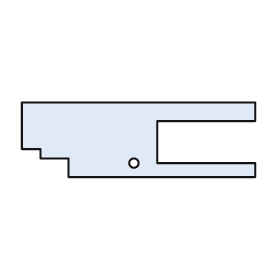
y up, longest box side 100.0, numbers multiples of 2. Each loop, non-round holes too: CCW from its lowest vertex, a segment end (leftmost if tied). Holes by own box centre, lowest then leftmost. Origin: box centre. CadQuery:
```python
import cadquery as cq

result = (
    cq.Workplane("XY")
    .moveTo(-30.0, -16.0)
    .lineTo(50.0, -16.0)
    .lineTo(50.0, -10.0)
    .lineTo(8.0, -10.0)
    .lineTo(8.0, 8.0)
    .lineTo(50.0, 8.0)
    .lineTo(50.0, 16.0)
    .lineTo(-50.0, 16.0)
    .lineTo(-50.0, -4.0)
    .lineTo(-42.0, -4.0)
    .lineTo(-42.0, -8.0)
    .lineTo(-30.0, -8.0)
    .close()
    .moveTo(-2.0, -10.0)
    .circle(2.0)
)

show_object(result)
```